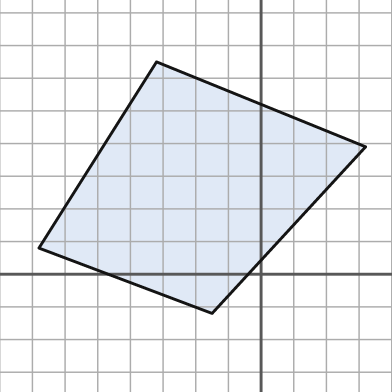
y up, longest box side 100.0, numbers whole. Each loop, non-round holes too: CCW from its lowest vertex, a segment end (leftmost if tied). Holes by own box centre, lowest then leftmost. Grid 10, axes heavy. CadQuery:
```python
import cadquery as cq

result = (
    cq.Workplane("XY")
    .moveTo(-15.0, -12.0)
    .lineTo(32.0, 39.0)
    .lineTo(-32.0, 65.0)
    .lineTo(-68.0, 8.0)
    .close()
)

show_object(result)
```